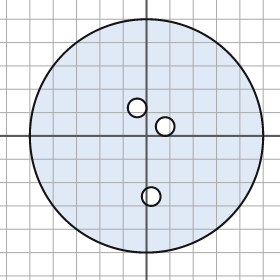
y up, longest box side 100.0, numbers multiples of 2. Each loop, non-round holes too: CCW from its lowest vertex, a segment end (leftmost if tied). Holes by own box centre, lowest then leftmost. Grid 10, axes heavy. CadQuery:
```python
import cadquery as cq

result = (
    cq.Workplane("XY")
    .moveTo(0.0, 0.0)
    .circle(50.0)
    .moveTo(2.0, -26.0)
    .circle(4.0)
    .moveTo(8.0, 4.0)
    .circle(4.0)
    .moveTo(-4.0, 12.0)
    .circle(4.0)
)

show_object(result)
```